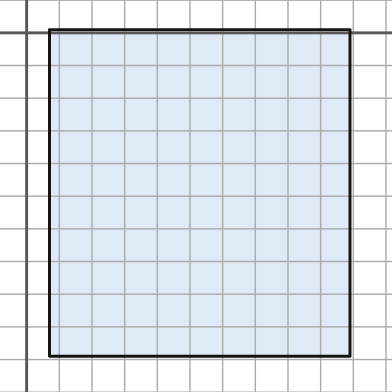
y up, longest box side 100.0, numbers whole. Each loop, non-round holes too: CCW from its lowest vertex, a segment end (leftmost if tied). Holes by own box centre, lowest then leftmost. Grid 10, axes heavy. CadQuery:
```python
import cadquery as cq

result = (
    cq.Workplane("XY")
    .moveTo(7.0, -99.0)
    .lineTo(99.0, -99.0)
    .lineTo(99.0, 1.0)
    .lineTo(7.0, 1.0)
    .close()
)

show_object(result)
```